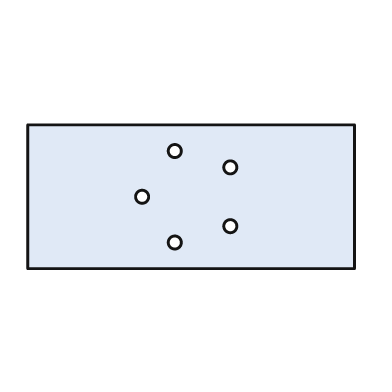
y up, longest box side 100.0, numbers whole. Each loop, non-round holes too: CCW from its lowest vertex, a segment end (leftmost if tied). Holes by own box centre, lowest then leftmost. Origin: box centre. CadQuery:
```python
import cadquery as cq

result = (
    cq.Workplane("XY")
    .moveTo(-50.0, -22.0)
    .lineTo(50.0, -22.0)
    .lineTo(50.0, 22.0)
    .lineTo(-50.0, 22.0)
    .close()
    .moveTo(-5.0, -14.0)
    .circle(2.0)
    .moveTo(12.0, -9.0)
    .circle(2.0)
    .moveTo(-15.0, 0.0)
    .circle(2.0)
    .moveTo(12.0, 9.0)
    .circle(2.0)
    .moveTo(-5.0, 14.0)
    .circle(2.0)
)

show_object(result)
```